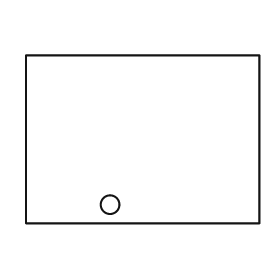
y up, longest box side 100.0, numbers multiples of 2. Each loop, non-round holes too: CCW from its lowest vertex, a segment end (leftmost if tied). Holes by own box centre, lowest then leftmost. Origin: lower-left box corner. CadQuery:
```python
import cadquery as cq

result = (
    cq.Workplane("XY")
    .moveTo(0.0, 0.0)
    .lineTo(100.0, 0.0)
    .lineTo(100.0, 72.0)
    .lineTo(0.0, 72.0)
    .close()
    .moveTo(36.0, 8.0)
    .circle(4.0)
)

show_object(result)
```